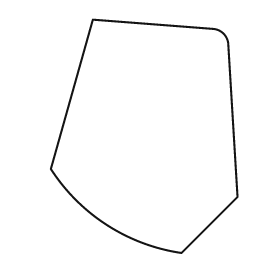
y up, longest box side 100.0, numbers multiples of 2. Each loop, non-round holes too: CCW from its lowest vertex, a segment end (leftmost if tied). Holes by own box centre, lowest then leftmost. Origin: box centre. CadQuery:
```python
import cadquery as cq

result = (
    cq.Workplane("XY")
    .moveTo(16.0, -50.0)
    .lineTo(40.0, -26.0)
    .lineTo(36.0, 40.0)
    .threePointArc((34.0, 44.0), (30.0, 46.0))
    .lineTo(-22.0, 50.0)
    .lineTo(-40.0, -14.0)
    .threePointArc((-16.0, -38.0), (16.0, -50.0))
    .close()
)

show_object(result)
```